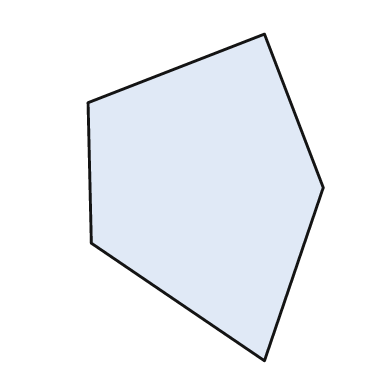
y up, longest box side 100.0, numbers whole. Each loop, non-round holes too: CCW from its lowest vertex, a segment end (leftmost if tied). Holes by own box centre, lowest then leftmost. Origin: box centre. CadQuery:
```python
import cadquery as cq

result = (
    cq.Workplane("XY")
    .moveTo(18.0, -50.0)
    .lineTo(36.0, 3.0)
    .lineTo(18.0, 50.0)
    .lineTo(-36.0, 29.0)
    .lineTo(-35.0, -14.0)
    .close()
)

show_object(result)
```